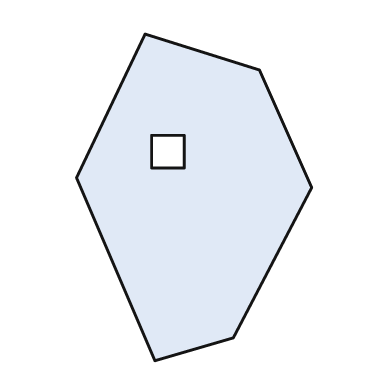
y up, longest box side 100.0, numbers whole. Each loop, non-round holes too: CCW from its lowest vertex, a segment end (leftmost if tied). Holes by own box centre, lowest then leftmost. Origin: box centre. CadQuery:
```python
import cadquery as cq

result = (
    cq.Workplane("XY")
    .moveTo(-12.0, -50.0)
    .lineTo(12.0, -43.0)
    .lineTo(36.0, 3.0)
    .lineTo(20.0, 39.0)
    .lineTo(-15.0, 50.0)
    .lineTo(-36.0, 6.0)
    .close()
    .moveTo(-13.0, 9.0)
    .lineTo(-3.0, 9.0)
    .lineTo(-3.0, 19.0)
    .lineTo(-13.0, 19.0)
    .close()
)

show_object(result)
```